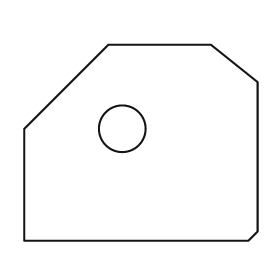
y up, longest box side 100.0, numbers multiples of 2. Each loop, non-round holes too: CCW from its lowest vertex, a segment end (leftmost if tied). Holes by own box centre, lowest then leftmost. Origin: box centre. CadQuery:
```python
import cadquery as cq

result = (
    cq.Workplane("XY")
    .moveTo(-50.0, -42.0)
    .lineTo(46.0, -42.0)
    .lineTo(50.0, -38.0)
    .lineTo(50.0, 26.0)
    .lineTo(30.0, 42.0)
    .lineTo(-14.0, 42.0)
    .lineTo(-50.0, 6.0)
    .close()
    .moveTo(-8.0, 6.0)
    .circle(10.0)
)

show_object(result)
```